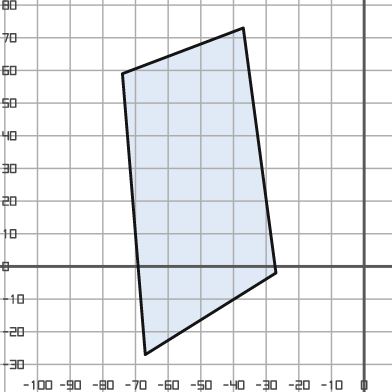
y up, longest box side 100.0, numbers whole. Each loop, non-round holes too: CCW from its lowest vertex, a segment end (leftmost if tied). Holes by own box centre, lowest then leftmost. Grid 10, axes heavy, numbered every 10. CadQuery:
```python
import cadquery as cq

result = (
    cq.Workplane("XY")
    .moveTo(-67.0, -27.0)
    .lineTo(-27.0, -2.0)
    .lineTo(-37.0, 73.0)
    .lineTo(-74.0, 59.0)
    .close()
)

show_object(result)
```